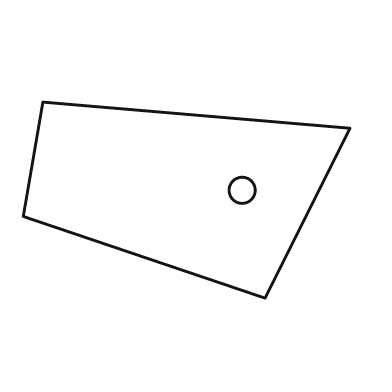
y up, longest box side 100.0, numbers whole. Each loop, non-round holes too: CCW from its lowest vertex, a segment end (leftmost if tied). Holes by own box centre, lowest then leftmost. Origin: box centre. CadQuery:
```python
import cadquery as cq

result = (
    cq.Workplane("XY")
    .moveTo(24.0, -30.0)
    .lineTo(50.0, 22.0)
    .lineTo(-44.0, 30.0)
    .lineTo(-50.0, -5.0)
    .close()
    .moveTo(17.0, 3.0)
    .circle(4.0)
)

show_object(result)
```